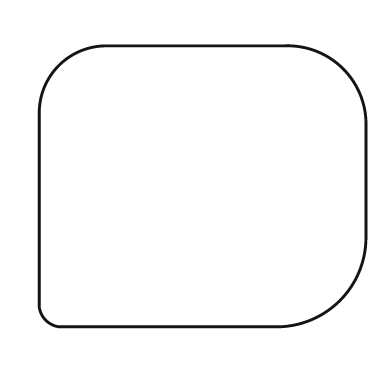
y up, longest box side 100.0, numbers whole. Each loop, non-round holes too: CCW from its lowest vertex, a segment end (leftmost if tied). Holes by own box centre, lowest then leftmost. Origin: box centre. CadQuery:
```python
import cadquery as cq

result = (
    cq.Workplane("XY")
    .moveTo(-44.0, -43.0)
    .lineTo(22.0, -43.0)
    .threePointArc((42.0, -35.0), (50.0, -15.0))
    .lineTo(50.0, 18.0)
    .threePointArc((43.0, 36.0), (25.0, 43.0))
    .lineTo(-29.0, 43.0)
    .threePointArc((-44.0, 37.0), (-50.0, 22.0))
    .lineTo(-50.0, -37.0)
    .threePointArc((-48.0, -41.0), (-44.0, -43.0))
    .close()
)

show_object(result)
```